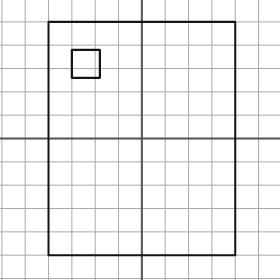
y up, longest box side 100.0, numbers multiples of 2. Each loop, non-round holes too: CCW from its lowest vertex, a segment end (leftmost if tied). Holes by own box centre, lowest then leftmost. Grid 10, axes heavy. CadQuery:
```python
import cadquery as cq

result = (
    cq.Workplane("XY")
    .moveTo(-40.0, -50.0)
    .lineTo(40.0, -50.0)
    .lineTo(40.0, 50.0)
    .lineTo(-40.0, 50.0)
    .close()
    .moveTo(-30.0, 26.0)
    .lineTo(-18.0, 26.0)
    .lineTo(-18.0, 38.0)
    .lineTo(-30.0, 38.0)
    .close()
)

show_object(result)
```